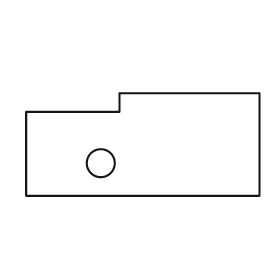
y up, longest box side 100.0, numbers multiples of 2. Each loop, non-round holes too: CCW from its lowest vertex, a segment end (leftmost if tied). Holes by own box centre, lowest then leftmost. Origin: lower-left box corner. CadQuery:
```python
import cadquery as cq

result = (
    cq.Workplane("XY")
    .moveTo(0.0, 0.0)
    .lineTo(100.0, 0.0)
    .lineTo(100.0, 44.0)
    .lineTo(40.0, 44.0)
    .lineTo(40.0, 36.0)
    .lineTo(0.0, 36.0)
    .close()
    .moveTo(32.0, 14.0)
    .circle(6.0)
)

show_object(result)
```